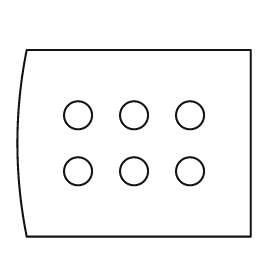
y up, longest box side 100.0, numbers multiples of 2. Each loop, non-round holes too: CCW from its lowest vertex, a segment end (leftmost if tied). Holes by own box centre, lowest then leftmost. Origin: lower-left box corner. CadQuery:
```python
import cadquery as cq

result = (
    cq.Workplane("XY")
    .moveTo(4.0, 0.0)
    .lineTo(100.0, 0.0)
    .lineTo(100.0, 80.0)
    .lineTo(4.0, 80.0)
    .threePointArc((0.0, 40.0), (4.0, 0.0))
    .close()
    .moveTo(26.0, 28.0)
    .circle(6.0)
    .moveTo(50.0, 28.0)
    .circle(6.0)
    .moveTo(74.0, 28.0)
    .circle(6.0)
    .moveTo(26.0, 52.0)
    .circle(6.0)
    .moveTo(50.0, 52.0)
    .circle(6.0)
    .moveTo(74.0, 52.0)
    .circle(6.0)
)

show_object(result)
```